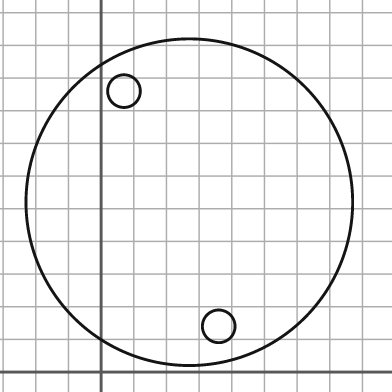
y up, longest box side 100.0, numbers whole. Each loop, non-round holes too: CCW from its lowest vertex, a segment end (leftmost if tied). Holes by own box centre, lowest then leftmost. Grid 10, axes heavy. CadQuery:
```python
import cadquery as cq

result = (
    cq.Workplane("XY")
    .moveTo(27.0, 52.0)
    .circle(50.0)
    .moveTo(36.0, 14.0)
    .circle(5.0)
    .moveTo(7.0, 86.0)
    .circle(5.0)
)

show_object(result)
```